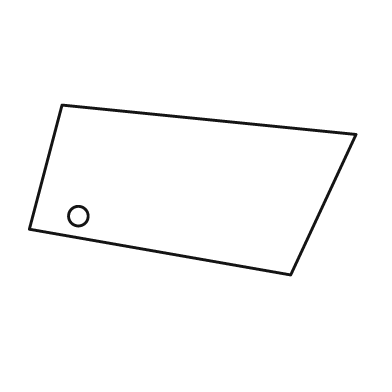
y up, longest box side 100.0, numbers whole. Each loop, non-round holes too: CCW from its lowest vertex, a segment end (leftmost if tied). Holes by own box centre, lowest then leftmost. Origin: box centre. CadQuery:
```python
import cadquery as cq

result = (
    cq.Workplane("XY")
    .moveTo(30.0, -26.0)
    .lineTo(50.0, 17.0)
    .lineTo(-40.0, 26.0)
    .lineTo(-50.0, -12.0)
    .close()
    .moveTo(-35.0, -8.0)
    .circle(3.0)
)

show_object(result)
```